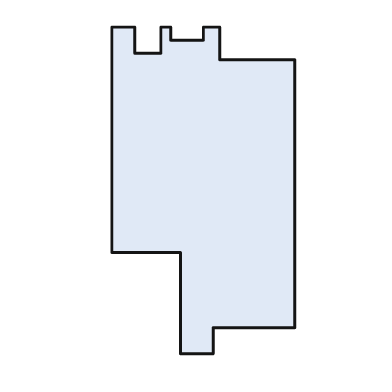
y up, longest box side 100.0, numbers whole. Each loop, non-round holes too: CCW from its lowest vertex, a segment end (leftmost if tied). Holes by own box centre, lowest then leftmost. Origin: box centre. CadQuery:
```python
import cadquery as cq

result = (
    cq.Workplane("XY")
    .moveTo(-7.0, -50.0)
    .lineTo(3.0, -50.0)
    .lineTo(3.0, -42.0)
    .lineTo(28.0, -42.0)
    .lineTo(28.0, 40.0)
    .lineTo(5.0, 40.0)
    .lineTo(5.0, 50.0)
    .lineTo(0.0, 50.0)
    .lineTo(0.0, 46.0)
    .lineTo(-10.0, 46.0)
    .lineTo(-10.0, 50.0)
    .lineTo(-13.0, 50.0)
    .lineTo(-13.0, 42.0)
    .lineTo(-21.0, 42.0)
    .lineTo(-21.0, 50.0)
    .lineTo(-28.0, 50.0)
    .lineTo(-28.0, -19.0)
    .lineTo(-7.0, -19.0)
    .close()
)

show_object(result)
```